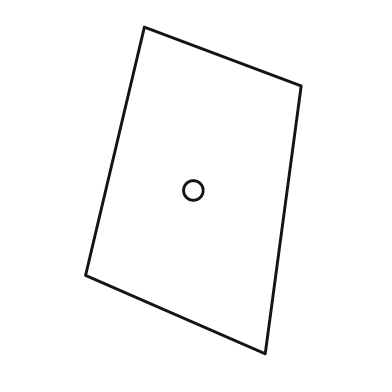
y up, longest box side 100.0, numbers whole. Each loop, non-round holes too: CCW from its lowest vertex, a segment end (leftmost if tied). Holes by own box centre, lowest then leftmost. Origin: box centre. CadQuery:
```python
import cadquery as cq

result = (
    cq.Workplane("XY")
    .moveTo(22.0, -50.0)
    .lineTo(33.0, 32.0)
    .lineTo(-15.0, 50.0)
    .lineTo(-33.0, -26.0)
    .close()
    .moveTo(0.0, 0.0)
    .circle(3.0)
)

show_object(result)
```